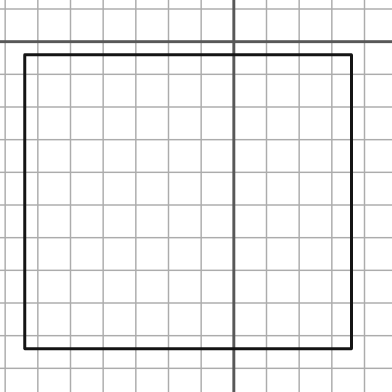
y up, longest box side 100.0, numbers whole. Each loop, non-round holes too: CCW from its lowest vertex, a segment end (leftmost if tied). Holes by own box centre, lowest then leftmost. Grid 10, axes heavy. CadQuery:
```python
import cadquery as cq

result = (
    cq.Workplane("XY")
    .moveTo(-64.0, -94.0)
    .lineTo(36.0, -94.0)
    .lineTo(36.0, -4.0)
    .lineTo(-64.0, -4.0)
    .close()
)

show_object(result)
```